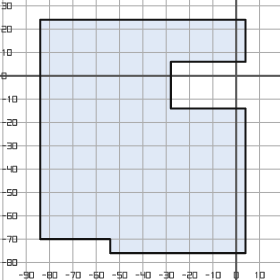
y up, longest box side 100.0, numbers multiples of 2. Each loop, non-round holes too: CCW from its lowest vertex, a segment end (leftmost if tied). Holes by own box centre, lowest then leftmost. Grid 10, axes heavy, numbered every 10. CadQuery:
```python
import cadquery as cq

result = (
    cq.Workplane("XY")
    .moveTo(-54.0, -76.0)
    .lineTo(4.0, -76.0)
    .lineTo(4.0, -14.0)
    .lineTo(-28.0, -14.0)
    .lineTo(-28.0, 6.0)
    .lineTo(4.0, 6.0)
    .lineTo(4.0, 24.0)
    .lineTo(-84.0, 24.0)
    .lineTo(-84.0, -70.0)
    .lineTo(-54.0, -70.0)
    .close()
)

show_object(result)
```